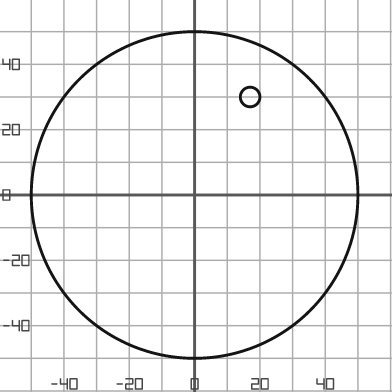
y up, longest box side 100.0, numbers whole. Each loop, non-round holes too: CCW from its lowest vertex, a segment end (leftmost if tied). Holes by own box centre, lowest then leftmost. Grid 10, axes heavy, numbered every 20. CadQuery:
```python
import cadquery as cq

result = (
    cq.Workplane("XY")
    .moveTo(0.0, 0.0)
    .circle(50.0)
    .moveTo(17.0, 30.0)
    .circle(3.0)
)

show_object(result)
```